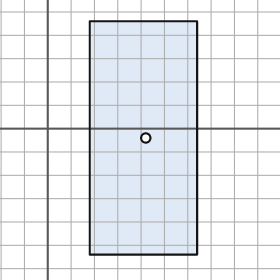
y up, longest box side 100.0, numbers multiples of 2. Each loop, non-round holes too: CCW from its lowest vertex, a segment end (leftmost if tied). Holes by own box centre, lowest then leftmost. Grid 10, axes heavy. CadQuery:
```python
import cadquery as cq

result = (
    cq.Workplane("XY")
    .moveTo(18.0, -54.0)
    .lineTo(64.0, -54.0)
    .lineTo(64.0, 46.0)
    .lineTo(18.0, 46.0)
    .close()
    .moveTo(42.0, -4.0)
    .circle(2.0)
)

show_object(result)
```